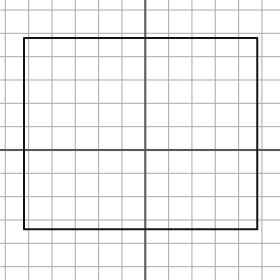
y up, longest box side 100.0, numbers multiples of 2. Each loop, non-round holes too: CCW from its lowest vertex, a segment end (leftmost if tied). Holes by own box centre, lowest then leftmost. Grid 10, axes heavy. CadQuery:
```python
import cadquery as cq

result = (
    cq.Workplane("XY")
    .moveTo(-52.0, -34.0)
    .lineTo(48.0, -34.0)
    .lineTo(48.0, 48.0)
    .lineTo(-52.0, 48.0)
    .close()
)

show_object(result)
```